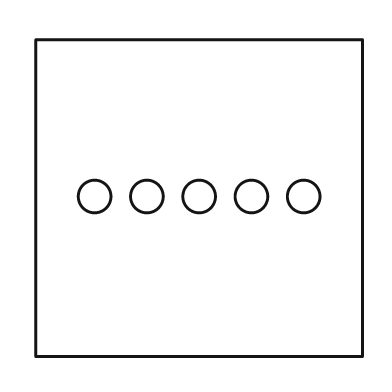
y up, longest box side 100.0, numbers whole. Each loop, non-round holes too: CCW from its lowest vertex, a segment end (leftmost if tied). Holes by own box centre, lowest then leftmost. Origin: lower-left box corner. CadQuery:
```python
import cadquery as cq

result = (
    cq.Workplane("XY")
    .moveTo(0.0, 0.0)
    .lineTo(100.0, 0.0)
    .lineTo(100.0, 97.0)
    .lineTo(0.0, 97.0)
    .close()
    .moveTo(18.0, 49.0)
    .circle(5.0)
    .moveTo(34.0, 49.0)
    .circle(5.0)
    .moveTo(50.0, 49.0)
    .circle(5.0)
    .moveTo(66.0, 49.0)
    .circle(5.0)
    .moveTo(82.0, 49.0)
    .circle(5.0)
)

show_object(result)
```